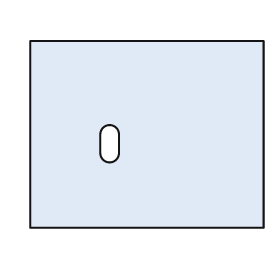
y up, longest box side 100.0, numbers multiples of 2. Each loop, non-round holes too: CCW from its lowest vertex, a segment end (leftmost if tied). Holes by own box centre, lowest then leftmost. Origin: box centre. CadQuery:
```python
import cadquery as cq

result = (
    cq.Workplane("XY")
    .moveTo(-50.0, -40.0)
    .lineTo(50.0, -40.0)
    .lineTo(50.0, 40.0)
    .lineTo(-50.0, 40.0)
    .close()
    .moveTo(-20.0, -8.0)
    .threePointArc((-16.0, -12.0), (-12.0, -8.0))
    .lineTo(-12.0, 0.0)
    .threePointArc((-16.0, 4.0), (-20.0, 0.0))
    .close()
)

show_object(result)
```